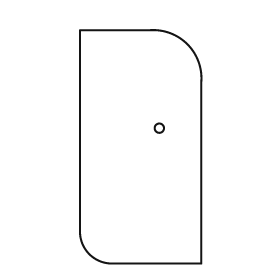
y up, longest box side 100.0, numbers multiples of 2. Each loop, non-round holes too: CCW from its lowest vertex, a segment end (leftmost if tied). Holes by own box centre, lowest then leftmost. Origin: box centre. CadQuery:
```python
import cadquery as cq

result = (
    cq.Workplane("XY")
    .moveTo(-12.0, -50.0)
    .lineTo(26.0, -50.0)
    .lineTo(26.0, 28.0)
    .threePointArc((20.0, 44.0), (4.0, 50.0))
    .lineTo(-26.0, 50.0)
    .lineTo(-26.0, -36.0)
    .threePointArc((-22.0, -46.0), (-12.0, -50.0))
    .close()
    .moveTo(8.0, 8.0)
    .circle(2.0)
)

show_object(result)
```